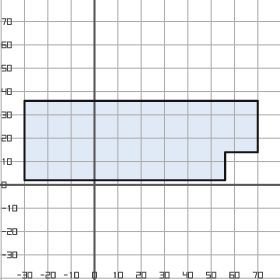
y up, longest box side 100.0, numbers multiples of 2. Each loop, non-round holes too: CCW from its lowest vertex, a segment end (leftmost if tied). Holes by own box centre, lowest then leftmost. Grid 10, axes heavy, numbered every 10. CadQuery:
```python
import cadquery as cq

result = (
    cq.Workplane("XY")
    .moveTo(-30.0, 2.0)
    .lineTo(56.0, 2.0)
    .lineTo(56.0, 14.0)
    .lineTo(70.0, 14.0)
    .lineTo(70.0, 36.0)
    .lineTo(-30.0, 36.0)
    .close()
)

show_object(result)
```